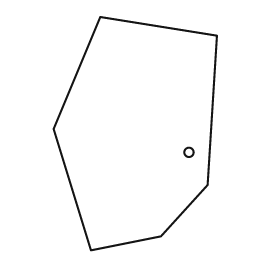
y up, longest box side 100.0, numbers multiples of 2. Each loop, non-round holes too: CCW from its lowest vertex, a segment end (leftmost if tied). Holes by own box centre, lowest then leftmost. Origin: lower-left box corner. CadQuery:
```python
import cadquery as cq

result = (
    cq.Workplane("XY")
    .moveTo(16.0, 0.0)
    .lineTo(46.0, 6.0)
    .lineTo(66.0, 28.0)
    .lineTo(70.0, 92.0)
    .lineTo(20.0, 100.0)
    .lineTo(0.0, 52.0)
    .close()
    .moveTo(58.0, 42.0)
    .circle(2.0)
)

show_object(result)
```